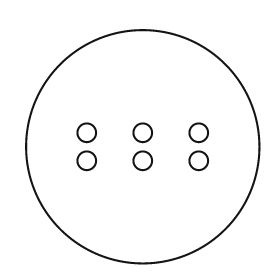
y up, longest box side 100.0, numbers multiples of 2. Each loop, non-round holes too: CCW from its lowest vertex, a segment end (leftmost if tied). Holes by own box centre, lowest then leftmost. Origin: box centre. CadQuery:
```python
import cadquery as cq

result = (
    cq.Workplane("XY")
    .moveTo(0.0, 0.0)
    .circle(50.0)
    .moveTo(-24.0, -6.0)
    .circle(4.0)
    .moveTo(0.0, -6.0)
    .circle(4.0)
    .moveTo(24.0, -6.0)
    .circle(4.0)
    .moveTo(-24.0, 6.0)
    .circle(4.0)
    .moveTo(0.0, 6.0)
    .circle(4.0)
    .moveTo(24.0, 6.0)
    .circle(4.0)
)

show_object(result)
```